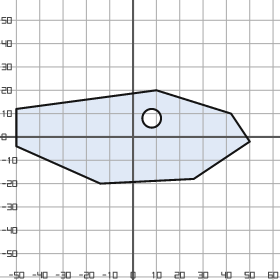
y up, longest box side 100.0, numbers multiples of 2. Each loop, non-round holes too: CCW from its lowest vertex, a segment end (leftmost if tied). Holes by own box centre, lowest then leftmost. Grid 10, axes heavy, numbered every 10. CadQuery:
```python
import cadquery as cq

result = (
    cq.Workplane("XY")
    .moveTo(-14.0, -20.0)
    .lineTo(26.0, -18.0)
    .lineTo(50.0, -2.0)
    .lineTo(42.0, 10.0)
    .lineTo(10.0, 20.0)
    .lineTo(-50.0, 12.0)
    .lineTo(-50.0, -4.0)
    .close()
    .moveTo(8.0, 8.0)
    .circle(4.0)
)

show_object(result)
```